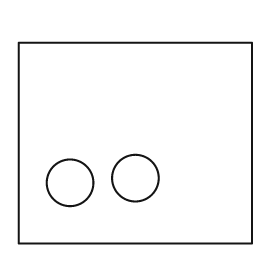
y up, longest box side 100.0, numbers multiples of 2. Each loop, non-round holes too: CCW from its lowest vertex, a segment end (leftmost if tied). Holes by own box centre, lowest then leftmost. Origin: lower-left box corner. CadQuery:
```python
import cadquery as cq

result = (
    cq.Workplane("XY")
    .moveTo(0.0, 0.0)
    .lineTo(100.0, 0.0)
    .lineTo(100.0, 86.0)
    .lineTo(0.0, 86.0)
    .close()
    .moveTo(22.0, 26.0)
    .circle(10.0)
    .moveTo(50.0, 28.0)
    .circle(10.0)
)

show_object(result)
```